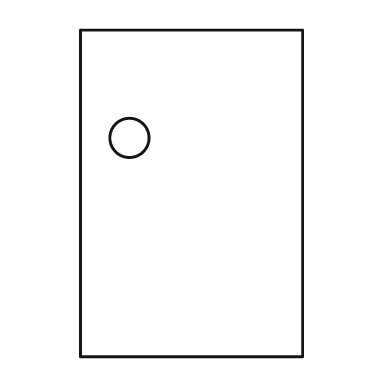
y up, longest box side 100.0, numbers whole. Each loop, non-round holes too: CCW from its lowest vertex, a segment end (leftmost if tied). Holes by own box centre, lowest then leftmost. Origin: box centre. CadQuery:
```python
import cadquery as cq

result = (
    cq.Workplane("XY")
    .moveTo(-34.0, -50.0)
    .lineTo(34.0, -50.0)
    .lineTo(34.0, 50.0)
    .lineTo(-34.0, 50.0)
    .close()
    .moveTo(-19.0, 17.0)
    .circle(6.0)
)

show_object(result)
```